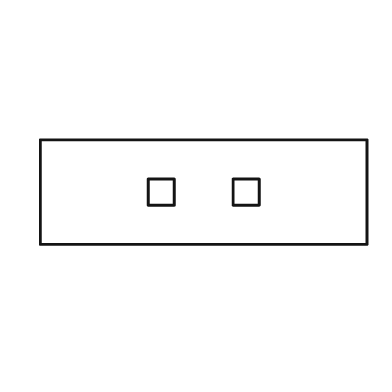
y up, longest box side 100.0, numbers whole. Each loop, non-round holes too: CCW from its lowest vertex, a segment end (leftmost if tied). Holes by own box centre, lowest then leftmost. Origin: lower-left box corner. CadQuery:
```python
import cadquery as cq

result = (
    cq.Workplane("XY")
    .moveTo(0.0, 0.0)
    .lineTo(100.0, 0.0)
    .lineTo(100.0, 32.0)
    .lineTo(0.0, 32.0)
    .close()
    .moveTo(33.0, 12.0)
    .lineTo(41.0, 12.0)
    .lineTo(41.0, 20.0)
    .lineTo(33.0, 20.0)
    .close()
    .moveTo(59.0, 12.0)
    .lineTo(67.0, 12.0)
    .lineTo(67.0, 20.0)
    .lineTo(59.0, 20.0)
    .close()
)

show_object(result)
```